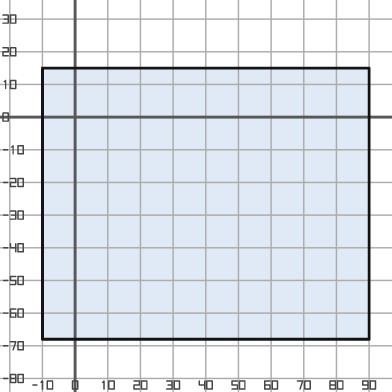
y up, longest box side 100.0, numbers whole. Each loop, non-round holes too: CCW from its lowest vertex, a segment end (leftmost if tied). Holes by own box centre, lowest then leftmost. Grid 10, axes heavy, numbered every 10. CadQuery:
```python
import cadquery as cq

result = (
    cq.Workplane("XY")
    .moveTo(-10.0, -68.0)
    .lineTo(90.0, -68.0)
    .lineTo(90.0, 15.0)
    .lineTo(-10.0, 15.0)
    .close()
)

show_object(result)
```